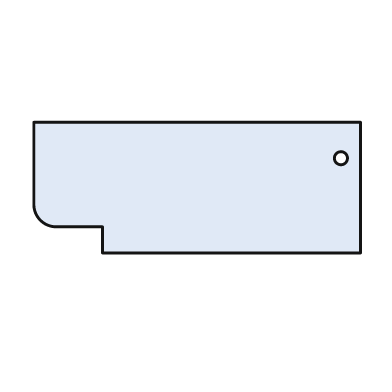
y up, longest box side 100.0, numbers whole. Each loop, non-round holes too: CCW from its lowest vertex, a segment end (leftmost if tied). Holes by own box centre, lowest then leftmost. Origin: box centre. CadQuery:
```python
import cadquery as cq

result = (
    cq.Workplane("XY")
    .moveTo(-29.0, -20.0)
    .lineTo(50.0, -20.0)
    .lineTo(50.0, 20.0)
    .lineTo(-50.0, 20.0)
    .lineTo(-50.0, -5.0)
    .threePointArc((-48.0, -10.0), (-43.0, -12.0))
    .lineTo(-29.0, -12.0)
    .close()
    .moveTo(44.0, 9.0)
    .circle(2.0)
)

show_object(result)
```